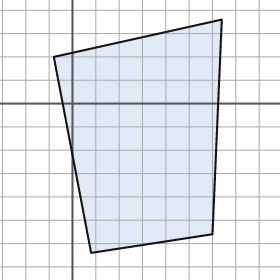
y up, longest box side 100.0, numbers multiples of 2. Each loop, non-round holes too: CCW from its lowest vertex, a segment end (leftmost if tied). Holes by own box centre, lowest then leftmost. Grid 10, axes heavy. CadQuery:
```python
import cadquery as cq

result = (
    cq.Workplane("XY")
    .moveTo(8.0, -64.0)
    .lineTo(60.0, -56.0)
    .lineTo(64.0, 36.0)
    .lineTo(-8.0, 20.0)
    .close()
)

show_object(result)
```